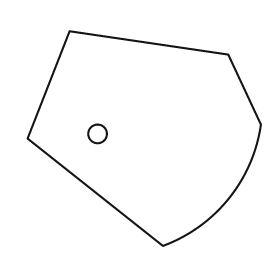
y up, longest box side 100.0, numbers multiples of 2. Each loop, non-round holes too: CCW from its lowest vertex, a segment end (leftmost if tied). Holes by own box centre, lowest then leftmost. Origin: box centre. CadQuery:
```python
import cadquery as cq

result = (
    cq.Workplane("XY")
    .moveTo(8.0, -46.0)
    .threePointArc((36.0, -26.0), (50.0, 6.0))
    .lineTo(36.0, 36.0)
    .lineTo(-32.0, 46.0)
    .lineTo(-50.0, 0.0)
    .close()
    .moveTo(-20.0, 2.0)
    .circle(4.0)
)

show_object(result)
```